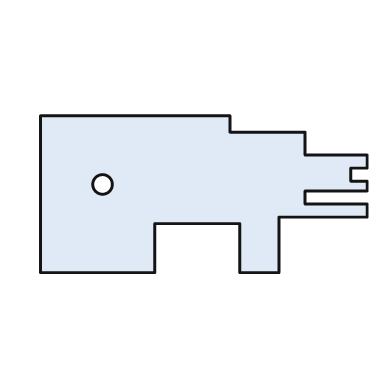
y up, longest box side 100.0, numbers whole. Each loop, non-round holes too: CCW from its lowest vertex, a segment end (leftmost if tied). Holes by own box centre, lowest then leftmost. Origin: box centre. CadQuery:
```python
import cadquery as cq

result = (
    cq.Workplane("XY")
    .moveTo(-50.0, -24.0)
    .lineTo(-15.0, -24.0)
    .lineTo(-15.0, -9.0)
    .lineTo(11.0, -9.0)
    .lineTo(11.0, -24.0)
    .lineTo(23.0, -24.0)
    .lineTo(23.0, -7.0)
    .lineTo(50.0, -7.0)
    .lineTo(50.0, -3.0)
    .lineTo(31.0, -3.0)
    .lineTo(31.0, 1.0)
    .lineTo(50.0, 1.0)
    .lineTo(50.0, 4.0)
    .lineTo(45.0, 4.0)
    .lineTo(45.0, 8.0)
    .lineTo(50.0, 8.0)
    .lineTo(50.0, 12.0)
    .lineTo(31.0, 12.0)
    .lineTo(31.0, 19.0)
    .lineTo(8.0, 19.0)
    .lineTo(8.0, 24.0)
    .lineTo(-50.0, 24.0)
    .close()
    .moveTo(-31.0, 3.0)
    .circle(3.0)
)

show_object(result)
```